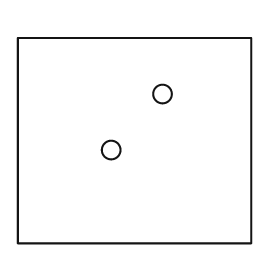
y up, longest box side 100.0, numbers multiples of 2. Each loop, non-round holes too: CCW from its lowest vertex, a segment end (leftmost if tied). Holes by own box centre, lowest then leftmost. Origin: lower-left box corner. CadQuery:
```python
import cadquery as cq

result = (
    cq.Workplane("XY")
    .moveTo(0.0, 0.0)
    .lineTo(100.0, 0.0)
    .lineTo(100.0, 88.0)
    .lineTo(0.0, 88.0)
    .close()
    .moveTo(40.0, 40.0)
    .circle(4.0)
    .moveTo(62.0, 64.0)
    .circle(4.0)
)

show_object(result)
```